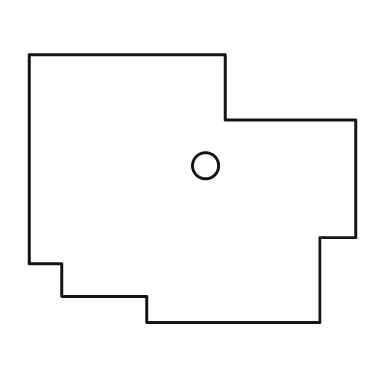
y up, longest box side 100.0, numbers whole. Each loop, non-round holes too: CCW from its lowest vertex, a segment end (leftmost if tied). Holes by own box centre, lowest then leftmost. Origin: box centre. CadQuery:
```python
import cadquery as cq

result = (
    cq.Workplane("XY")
    .moveTo(-14.0, -41.0)
    .lineTo(39.0, -41.0)
    .lineTo(39.0, -15.0)
    .lineTo(50.0, -15.0)
    .lineTo(50.0, 21.0)
    .lineTo(10.0, 21.0)
    .lineTo(10.0, 41.0)
    .lineTo(-50.0, 41.0)
    .lineTo(-50.0, -23.0)
    .lineTo(-40.0, -23.0)
    .lineTo(-40.0, -33.0)
    .lineTo(-14.0, -33.0)
    .close()
    .moveTo(4.0, 7.0)
    .circle(4.0)
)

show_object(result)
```